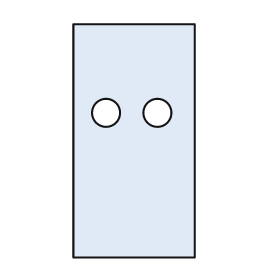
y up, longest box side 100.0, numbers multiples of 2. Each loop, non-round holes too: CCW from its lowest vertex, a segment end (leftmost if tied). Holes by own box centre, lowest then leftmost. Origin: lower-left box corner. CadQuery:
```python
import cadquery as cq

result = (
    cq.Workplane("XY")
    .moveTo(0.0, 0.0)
    .lineTo(52.0, 0.0)
    .lineTo(52.0, 100.0)
    .lineTo(0.0, 100.0)
    .close()
    .moveTo(14.0, 62.0)
    .circle(6.0)
    .moveTo(36.0, 62.0)
    .circle(6.0)
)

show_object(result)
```